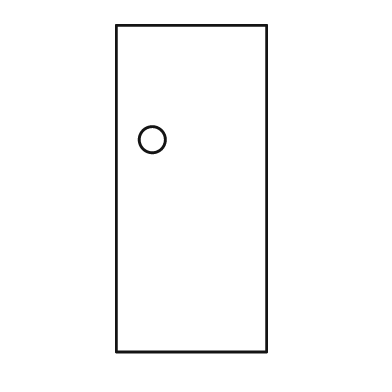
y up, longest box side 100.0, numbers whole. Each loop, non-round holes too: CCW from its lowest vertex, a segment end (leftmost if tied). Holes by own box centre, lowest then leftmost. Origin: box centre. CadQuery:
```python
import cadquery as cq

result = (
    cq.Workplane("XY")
    .moveTo(-23.0, -50.0)
    .lineTo(23.0, -50.0)
    .lineTo(23.0, 50.0)
    .lineTo(-23.0, 50.0)
    .close()
    .moveTo(-12.0, 15.0)
    .circle(4.0)
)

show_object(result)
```